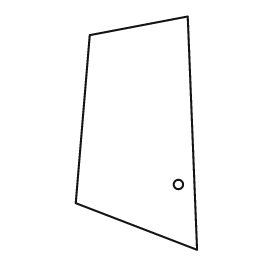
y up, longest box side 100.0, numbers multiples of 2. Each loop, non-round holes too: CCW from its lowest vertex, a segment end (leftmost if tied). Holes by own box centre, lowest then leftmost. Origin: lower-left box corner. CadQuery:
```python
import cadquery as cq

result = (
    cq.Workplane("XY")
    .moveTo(52.0, 0.0)
    .lineTo(48.0, 100.0)
    .lineTo(6.0, 92.0)
    .lineTo(0.0, 20.0)
    .close()
    .moveTo(44.0, 28.0)
    .circle(2.0)
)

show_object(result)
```